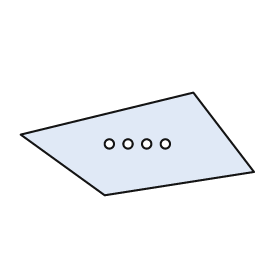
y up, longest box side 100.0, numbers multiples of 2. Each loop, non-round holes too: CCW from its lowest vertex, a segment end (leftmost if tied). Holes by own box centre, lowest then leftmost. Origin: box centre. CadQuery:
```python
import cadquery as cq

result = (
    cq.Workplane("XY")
    .moveTo(-14.0, -22.0)
    .lineTo(50.0, -12.0)
    .lineTo(24.0, 22.0)
    .lineTo(-50.0, 4.0)
    .close()
    .moveTo(-12.0, 0.0)
    .circle(2.0)
    .moveTo(-4.0, 0.0)
    .circle(2.0)
    .moveTo(4.0, 0.0)
    .circle(2.0)
    .moveTo(12.0, 0.0)
    .circle(2.0)
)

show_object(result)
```